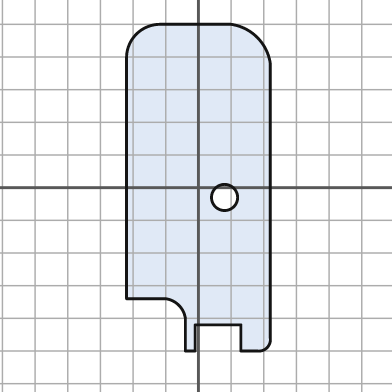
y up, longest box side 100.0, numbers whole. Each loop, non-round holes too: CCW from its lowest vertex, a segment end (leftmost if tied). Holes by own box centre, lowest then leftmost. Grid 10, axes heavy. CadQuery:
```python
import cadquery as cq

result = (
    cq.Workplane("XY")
    .moveTo(-4.0, -50.0)
    .lineTo(-1.0, -50.0)
    .lineTo(-1.0, -42.0)
    .lineTo(13.0, -42.0)
    .lineTo(13.0, -50.0)
    .lineTo(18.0, -50.0)
    .threePointArc((21.0, -49.0), (22.0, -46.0))
    .lineTo(22.0, 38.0)
    .threePointArc((18.0, 46.0), (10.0, 50.0))
    .lineTo(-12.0, 50.0)
    .threePointArc((-19.0, 47.0), (-22.0, 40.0))
    .lineTo(-22.0, -34.0)
    .lineTo(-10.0, -34.0)
    .threePointArc((-6.0, -36.0), (-4.0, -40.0))
    .close()
    .moveTo(8.0, -3.0)
    .circle(4.0)
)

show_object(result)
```